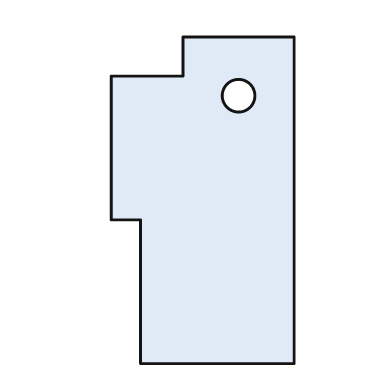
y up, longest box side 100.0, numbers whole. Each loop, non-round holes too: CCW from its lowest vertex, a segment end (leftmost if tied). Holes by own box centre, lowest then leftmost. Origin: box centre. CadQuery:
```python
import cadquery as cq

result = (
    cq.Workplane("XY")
    .moveTo(-19.0, -50.0)
    .lineTo(28.0, -50.0)
    .lineTo(28.0, 50.0)
    .lineTo(-6.0, 50.0)
    .lineTo(-6.0, 38.0)
    .lineTo(-28.0, 38.0)
    .lineTo(-28.0, -6.0)
    .lineTo(-19.0, -6.0)
    .close()
    .moveTo(11.0, 32.0)
    .circle(5.0)
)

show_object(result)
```